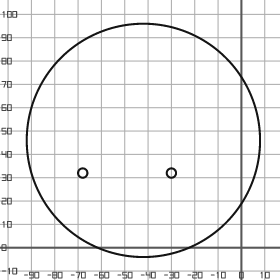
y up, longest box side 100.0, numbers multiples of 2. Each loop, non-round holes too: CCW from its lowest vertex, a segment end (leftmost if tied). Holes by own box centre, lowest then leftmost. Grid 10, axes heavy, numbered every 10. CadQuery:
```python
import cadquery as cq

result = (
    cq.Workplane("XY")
    .moveTo(-42.0, 46.0)
    .circle(50.0)
    .moveTo(-68.0, 32.0)
    .circle(2.0)
    .moveTo(-30.0, 32.0)
    .circle(2.0)
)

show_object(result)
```